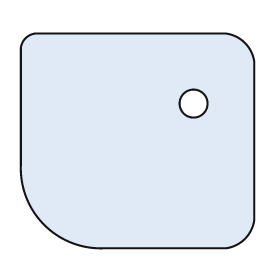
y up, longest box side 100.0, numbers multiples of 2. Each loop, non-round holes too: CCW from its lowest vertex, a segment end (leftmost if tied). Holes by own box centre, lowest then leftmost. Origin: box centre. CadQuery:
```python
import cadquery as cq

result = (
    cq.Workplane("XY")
    .moveTo(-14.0, -46.0)
    .lineTo(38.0, -46.0)
    .threePointArc((46.0, -42.0), (50.0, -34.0))
    .lineTo(50.0, 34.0)
    .threePointArc((46.0, 42.0), (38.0, 46.0))
    .lineTo(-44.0, 46.0)
    .threePointArc((-48.0, 44.0), (-50.0, 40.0))
    .lineTo(-50.0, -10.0)
    .threePointArc((-40.0, -36.0), (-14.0, -46.0))
    .close()
    .moveTo(24.0, 16.0)
    .circle(6.0)
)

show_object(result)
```